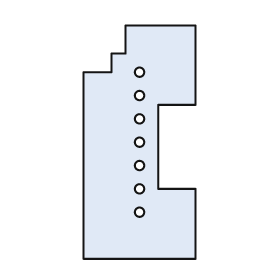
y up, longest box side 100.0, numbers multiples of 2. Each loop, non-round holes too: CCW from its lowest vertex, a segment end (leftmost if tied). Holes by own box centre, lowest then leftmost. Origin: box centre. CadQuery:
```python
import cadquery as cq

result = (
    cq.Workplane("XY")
    .moveTo(-24.0, -50.0)
    .lineTo(24.0, -50.0)
    .lineTo(24.0, -20.0)
    .lineTo(8.0, -20.0)
    .lineTo(8.0, 16.0)
    .lineTo(24.0, 16.0)
    .lineTo(24.0, 50.0)
    .lineTo(-6.0, 50.0)
    .lineTo(-6.0, 38.0)
    .lineTo(-12.0, 38.0)
    .lineTo(-12.0, 30.0)
    .lineTo(-24.0, 30.0)
    .close()
    .moveTo(0.0, -30.0)
    .circle(2.0)
    .moveTo(0.0, -20.0)
    .circle(2.0)
    .moveTo(0.0, -10.0)
    .circle(2.0)
    .moveTo(0.0, 0.0)
    .circle(2.0)
    .moveTo(0.0, 10.0)
    .circle(2.0)
    .moveTo(0.0, 20.0)
    .circle(2.0)
    .moveTo(0.0, 30.0)
    .circle(2.0)
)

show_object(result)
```